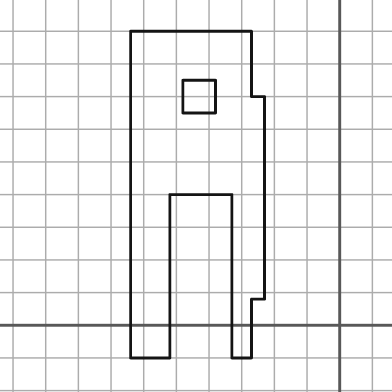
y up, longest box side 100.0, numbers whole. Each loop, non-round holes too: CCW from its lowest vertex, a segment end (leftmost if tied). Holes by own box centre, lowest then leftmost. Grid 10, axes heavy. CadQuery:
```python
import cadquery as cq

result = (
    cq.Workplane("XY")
    .moveTo(-64.0, -10.0)
    .lineTo(-52.0, -10.0)
    .lineTo(-52.0, 40.0)
    .lineTo(-33.0, 40.0)
    .lineTo(-33.0, -10.0)
    .lineTo(-27.0, -10.0)
    .lineTo(-27.0, 8.0)
    .lineTo(-23.0, 8.0)
    .lineTo(-23.0, 70.0)
    .lineTo(-27.0, 70.0)
    .lineTo(-27.0, 90.0)
    .lineTo(-64.0, 90.0)
    .close()
    .moveTo(-48.0, 65.0)
    .lineTo(-38.0, 65.0)
    .lineTo(-38.0, 75.0)
    .lineTo(-48.0, 75.0)
    .close()
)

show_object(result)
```